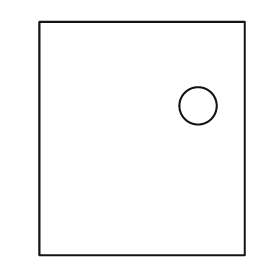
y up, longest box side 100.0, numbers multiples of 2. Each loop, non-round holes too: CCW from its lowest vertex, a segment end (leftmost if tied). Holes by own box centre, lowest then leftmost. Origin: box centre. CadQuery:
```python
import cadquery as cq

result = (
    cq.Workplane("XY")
    .moveTo(-44.0, -50.0)
    .lineTo(44.0, -50.0)
    .lineTo(44.0, 50.0)
    .lineTo(-44.0, 50.0)
    .close()
    .moveTo(24.0, 14.0)
    .circle(8.0)
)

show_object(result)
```